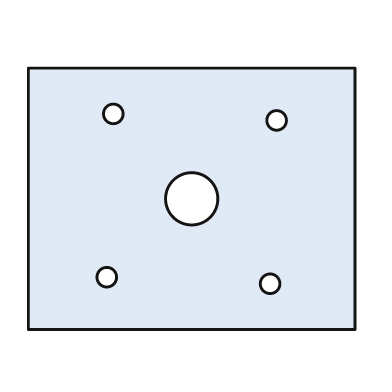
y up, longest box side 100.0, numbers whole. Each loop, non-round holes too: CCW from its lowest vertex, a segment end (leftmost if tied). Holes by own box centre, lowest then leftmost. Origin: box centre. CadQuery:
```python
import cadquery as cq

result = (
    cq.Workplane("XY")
    .moveTo(-50.0, -40.0)
    .lineTo(50.0, -40.0)
    .lineTo(50.0, 40.0)
    .lineTo(-50.0, 40.0)
    .close()
    .moveTo(24.0, -26.0)
    .circle(3.0)
    .moveTo(-26.0, -24.0)
    .circle(3.0)
    .moveTo(0.0, 0.0)
    .circle(8.0)
    .moveTo(26.0, 24.0)
    .circle(3.0)
    .moveTo(-24.0, 26.0)
    .circle(3.0)
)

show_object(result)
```